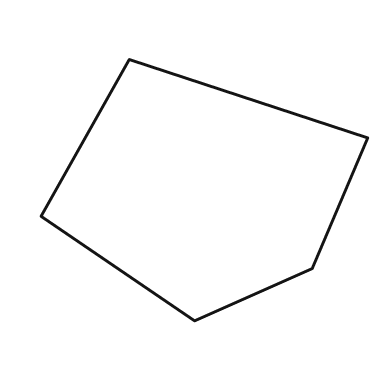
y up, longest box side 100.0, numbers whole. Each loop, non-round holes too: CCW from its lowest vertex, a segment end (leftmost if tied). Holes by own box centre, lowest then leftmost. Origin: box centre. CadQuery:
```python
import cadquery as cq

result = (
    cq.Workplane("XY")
    .moveTo(-3.0, -40.0)
    .lineTo(33.0, -24.0)
    .lineTo(50.0, 16.0)
    .lineTo(-23.0, 40.0)
    .lineTo(-50.0, -8.0)
    .close()
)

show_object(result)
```